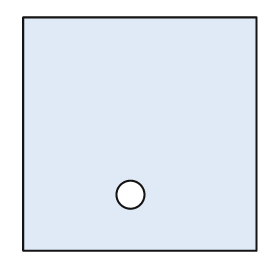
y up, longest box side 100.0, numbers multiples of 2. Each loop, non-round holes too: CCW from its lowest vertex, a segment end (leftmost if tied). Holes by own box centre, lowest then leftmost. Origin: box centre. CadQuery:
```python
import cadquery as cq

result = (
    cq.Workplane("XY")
    .moveTo(-50.0, -50.0)
    .lineTo(50.0, -50.0)
    .lineTo(50.0, 50.0)
    .lineTo(-50.0, 50.0)
    .close()
    .moveTo(-4.0, -26.0)
    .circle(6.0)
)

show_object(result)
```